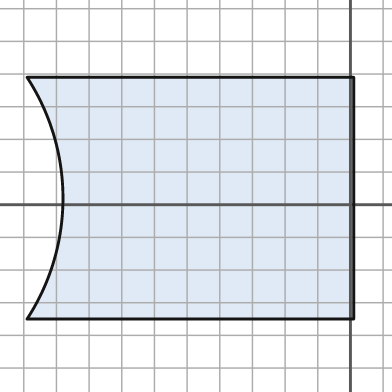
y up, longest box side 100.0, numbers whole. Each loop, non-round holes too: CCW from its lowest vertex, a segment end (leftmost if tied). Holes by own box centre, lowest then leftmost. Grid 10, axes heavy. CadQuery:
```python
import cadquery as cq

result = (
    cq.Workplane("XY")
    .moveTo(-99.0, -35.0)
    .lineTo(1.0, -35.0)
    .lineTo(1.0, 39.0)
    .lineTo(-99.0, 39.0)
    .threePointArc((-88.0, 2.0), (-99.0, -35.0))
    .close()
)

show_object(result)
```